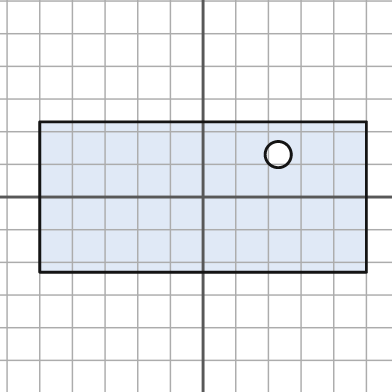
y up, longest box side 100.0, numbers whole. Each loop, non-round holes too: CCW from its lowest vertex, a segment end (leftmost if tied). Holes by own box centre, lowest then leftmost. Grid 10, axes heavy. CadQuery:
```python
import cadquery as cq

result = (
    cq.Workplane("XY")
    .moveTo(-50.0, -23.0)
    .lineTo(50.0, -23.0)
    .lineTo(50.0, 23.0)
    .lineTo(-50.0, 23.0)
    .close()
    .moveTo(23.0, 13.0)
    .circle(4.0)
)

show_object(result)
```